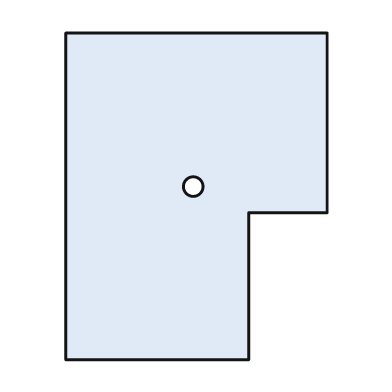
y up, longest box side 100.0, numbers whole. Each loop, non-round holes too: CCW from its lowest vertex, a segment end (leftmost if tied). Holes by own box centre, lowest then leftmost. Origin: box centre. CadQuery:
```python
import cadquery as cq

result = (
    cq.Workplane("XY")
    .moveTo(-40.0, -50.0)
    .lineTo(16.0, -50.0)
    .lineTo(16.0, -5.0)
    .lineTo(40.0, -5.0)
    .lineTo(40.0, 50.0)
    .lineTo(-40.0, 50.0)
    .close()
    .moveTo(-1.0, 3.0)
    .circle(3.0)
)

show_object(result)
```